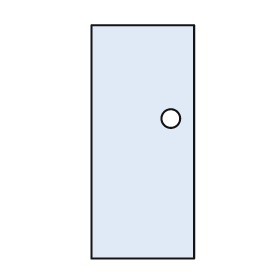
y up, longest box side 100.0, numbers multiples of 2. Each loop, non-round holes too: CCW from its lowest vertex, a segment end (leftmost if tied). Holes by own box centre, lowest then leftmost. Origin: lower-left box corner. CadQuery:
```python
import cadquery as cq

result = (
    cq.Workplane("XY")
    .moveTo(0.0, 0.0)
    .lineTo(44.0, 0.0)
    .lineTo(44.0, 100.0)
    .lineTo(0.0, 100.0)
    .close()
    .moveTo(34.0, 60.0)
    .circle(4.0)
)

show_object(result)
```